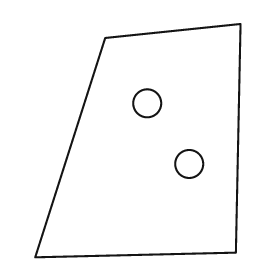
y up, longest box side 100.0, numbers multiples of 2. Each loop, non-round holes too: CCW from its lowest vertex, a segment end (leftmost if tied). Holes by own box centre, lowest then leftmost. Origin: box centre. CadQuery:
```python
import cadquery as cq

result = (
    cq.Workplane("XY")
    .moveTo(-44.0, -50.0)
    .lineTo(42.0, -48.0)
    .lineTo(44.0, 50.0)
    .lineTo(-14.0, 44.0)
    .close()
    .moveTo(22.0, -10.0)
    .circle(6.0)
    .moveTo(4.0, 16.0)
    .circle(6.0)
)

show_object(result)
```